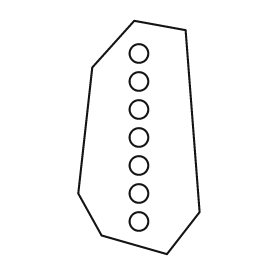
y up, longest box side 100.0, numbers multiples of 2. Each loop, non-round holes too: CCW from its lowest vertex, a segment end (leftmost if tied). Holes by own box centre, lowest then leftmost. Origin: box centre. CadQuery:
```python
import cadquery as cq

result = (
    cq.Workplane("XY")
    .moveTo(12.0, -50.0)
    .lineTo(26.0, -32.0)
    .lineTo(20.0, 46.0)
    .lineTo(-2.0, 50.0)
    .lineTo(-20.0, 30.0)
    .lineTo(-26.0, -24.0)
    .lineTo(-16.0, -42.0)
    .close()
    .moveTo(0.0, -36.0)
    .circle(4.0)
    .moveTo(0.0, -24.0)
    .circle(4.0)
    .moveTo(0.0, -12.0)
    .circle(4.0)
    .moveTo(0.0, 0.0)
    .circle(4.0)
    .moveTo(0.0, 12.0)
    .circle(4.0)
    .moveTo(0.0, 24.0)
    .circle(4.0)
    .moveTo(0.0, 36.0)
    .circle(4.0)
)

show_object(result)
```